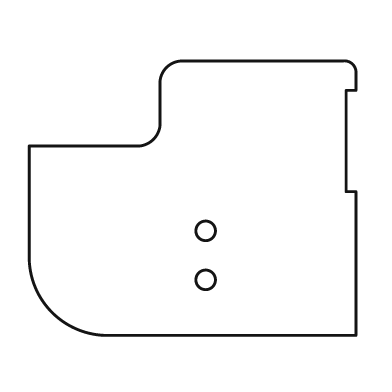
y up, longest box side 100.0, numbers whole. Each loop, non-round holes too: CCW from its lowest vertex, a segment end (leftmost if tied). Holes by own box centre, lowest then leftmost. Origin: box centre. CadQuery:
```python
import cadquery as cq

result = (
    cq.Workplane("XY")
    .moveTo(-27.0, -42.0)
    .lineTo(50.0, -42.0)
    .lineTo(50.0, 2.0)
    .lineTo(47.0, 2.0)
    .lineTo(47.0, 33.0)
    .lineTo(50.0, 33.0)
    .lineTo(50.0, 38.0)
    .threePointArc((49.0, 41.0), (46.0, 42.0))
    .lineTo(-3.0, 42.0)
    .threePointArc((-8.0, 40.0), (-10.0, 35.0))
    .lineTo(-10.0, 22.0)
    .threePointArc((-12.0, 18.0), (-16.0, 16.0))
    .lineTo(-50.0, 16.0)
    .lineTo(-50.0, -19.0)
    .threePointArc((-43.0, -35.0), (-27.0, -42.0))
    .close()
    .moveTo(4.0, -25.0)
    .circle(3.0)
    .moveTo(4.0, -10.0)
    .circle(3.0)
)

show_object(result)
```